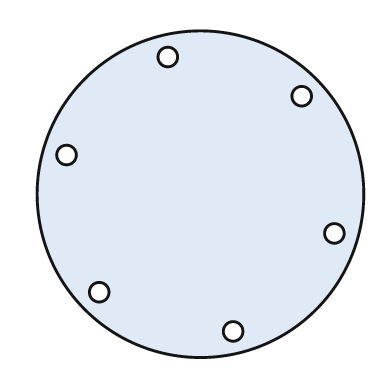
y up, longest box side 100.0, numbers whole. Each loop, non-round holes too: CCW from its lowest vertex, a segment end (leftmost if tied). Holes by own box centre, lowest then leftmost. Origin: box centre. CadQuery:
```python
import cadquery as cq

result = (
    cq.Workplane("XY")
    .moveTo(0.0, 0.0)
    .circle(50.0)
    .moveTo(10.0, -42.0)
    .circle(3.0)
    .moveTo(-31.0, -30.0)
    .circle(3.0)
    .moveTo(41.0, -12.0)
    .circle(3.0)
    .moveTo(-41.0, 12.0)
    .circle(3.0)
    .moveTo(31.0, 30.0)
    .circle(3.0)
    .moveTo(-10.0, 42.0)
    .circle(3.0)
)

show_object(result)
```